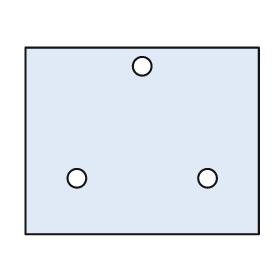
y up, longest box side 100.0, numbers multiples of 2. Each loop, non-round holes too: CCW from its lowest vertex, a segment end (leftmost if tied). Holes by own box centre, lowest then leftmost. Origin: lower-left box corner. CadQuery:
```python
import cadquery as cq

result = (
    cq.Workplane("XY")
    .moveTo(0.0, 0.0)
    .lineTo(100.0, 0.0)
    .lineTo(100.0, 80.0)
    .lineTo(0.0, 80.0)
    .close()
    .moveTo(22.0, 24.0)
    .circle(4.0)
    .moveTo(78.0, 24.0)
    .circle(4.0)
    .moveTo(50.0, 72.0)
    .circle(4.0)
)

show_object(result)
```